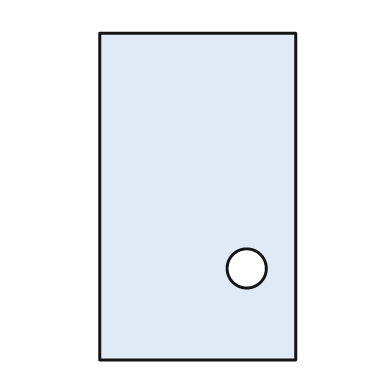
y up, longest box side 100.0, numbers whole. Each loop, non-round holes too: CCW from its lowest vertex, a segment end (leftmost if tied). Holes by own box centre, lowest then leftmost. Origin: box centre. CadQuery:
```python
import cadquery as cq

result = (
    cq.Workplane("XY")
    .moveTo(-30.0, -50.0)
    .lineTo(30.0, -50.0)
    .lineTo(30.0, 50.0)
    .lineTo(-30.0, 50.0)
    .close()
    .moveTo(15.0, -22.0)
    .circle(6.0)
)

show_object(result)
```